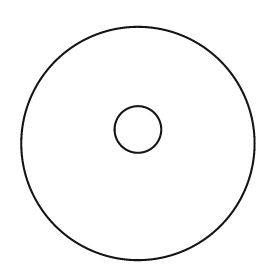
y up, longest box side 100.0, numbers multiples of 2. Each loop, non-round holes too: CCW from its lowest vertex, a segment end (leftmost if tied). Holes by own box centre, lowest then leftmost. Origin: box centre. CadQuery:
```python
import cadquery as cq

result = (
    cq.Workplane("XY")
    .moveTo(0.0, 0.0)
    .circle(50.0)
    .moveTo(0.0, 6.0)
    .circle(10.0)
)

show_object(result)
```